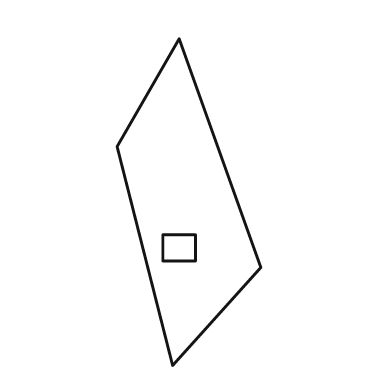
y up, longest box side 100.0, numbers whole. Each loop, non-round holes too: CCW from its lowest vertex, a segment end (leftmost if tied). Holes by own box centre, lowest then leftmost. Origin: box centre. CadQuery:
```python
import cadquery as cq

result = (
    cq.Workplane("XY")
    .moveTo(-5.0, -50.0)
    .lineTo(22.0, -20.0)
    .lineTo(-3.0, 50.0)
    .lineTo(-22.0, 17.0)
    .close()
    .moveTo(-8.0, -18.0)
    .lineTo(2.0, -18.0)
    .lineTo(2.0, -10.0)
    .lineTo(-8.0, -10.0)
    .close()
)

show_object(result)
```